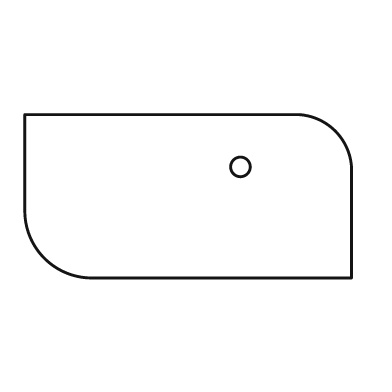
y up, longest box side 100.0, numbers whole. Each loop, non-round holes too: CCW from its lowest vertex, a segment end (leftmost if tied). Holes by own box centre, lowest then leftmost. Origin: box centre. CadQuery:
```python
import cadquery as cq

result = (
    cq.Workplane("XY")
    .moveTo(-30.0, -25.0)
    .lineTo(50.0, -25.0)
    .lineTo(50.0, 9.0)
    .threePointArc((45.0, 20.0), (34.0, 25.0))
    .lineTo(-50.0, 25.0)
    .lineTo(-50.0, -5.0)
    .threePointArc((-44.0, -19.0), (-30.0, -25.0))
    .close()
    .moveTo(16.0, 9.0)
    .circle(3.0)
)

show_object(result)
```